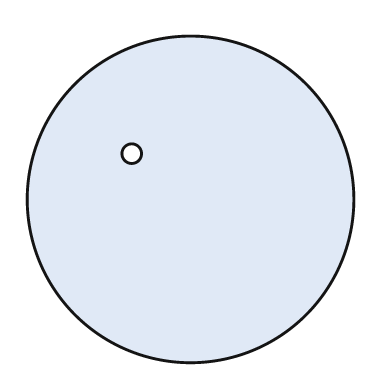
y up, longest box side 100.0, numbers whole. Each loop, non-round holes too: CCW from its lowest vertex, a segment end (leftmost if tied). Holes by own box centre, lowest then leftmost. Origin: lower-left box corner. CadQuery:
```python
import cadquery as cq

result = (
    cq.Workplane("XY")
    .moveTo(50.0, 50.0)
    .circle(50.0)
    .moveTo(32.0, 64.0)
    .circle(3.0)
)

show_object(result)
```